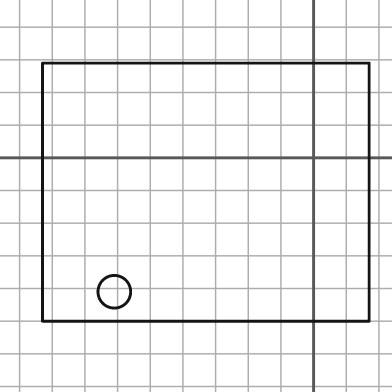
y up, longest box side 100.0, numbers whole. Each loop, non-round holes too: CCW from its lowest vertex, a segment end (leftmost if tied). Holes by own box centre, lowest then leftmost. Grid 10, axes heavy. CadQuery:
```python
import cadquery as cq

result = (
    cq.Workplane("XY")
    .moveTo(-83.0, -50.0)
    .lineTo(17.0, -50.0)
    .lineTo(17.0, 29.0)
    .lineTo(-83.0, 29.0)
    .close()
    .moveTo(-61.0, -41.0)
    .circle(5.0)
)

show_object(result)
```